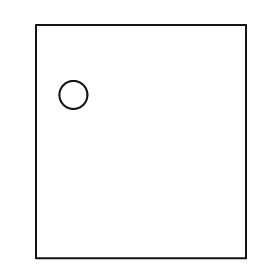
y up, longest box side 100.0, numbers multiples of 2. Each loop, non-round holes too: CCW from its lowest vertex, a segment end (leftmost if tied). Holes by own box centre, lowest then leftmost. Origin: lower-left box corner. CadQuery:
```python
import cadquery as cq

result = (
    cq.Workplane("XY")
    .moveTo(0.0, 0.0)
    .lineTo(90.0, 0.0)
    .lineTo(90.0, 100.0)
    .lineTo(0.0, 100.0)
    .close()
    .moveTo(16.0, 70.0)
    .circle(6.0)
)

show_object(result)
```